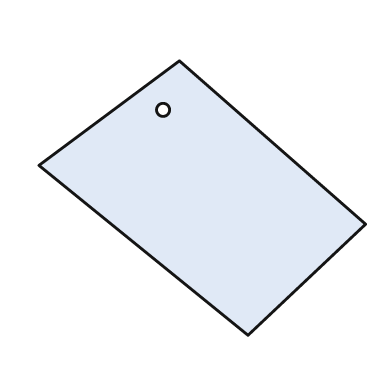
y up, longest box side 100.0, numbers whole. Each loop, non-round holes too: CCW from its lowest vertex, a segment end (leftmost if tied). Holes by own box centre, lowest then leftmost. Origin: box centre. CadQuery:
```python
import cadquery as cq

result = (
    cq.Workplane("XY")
    .moveTo(14.0, -42.0)
    .lineTo(50.0, -8.0)
    .lineTo(-7.0, 42.0)
    .lineTo(-50.0, 10.0)
    .close()
    .moveTo(-12.0, 27.0)
    .circle(2.0)
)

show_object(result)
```